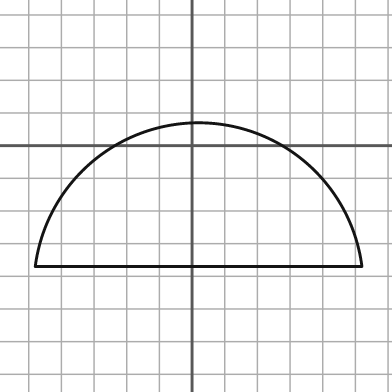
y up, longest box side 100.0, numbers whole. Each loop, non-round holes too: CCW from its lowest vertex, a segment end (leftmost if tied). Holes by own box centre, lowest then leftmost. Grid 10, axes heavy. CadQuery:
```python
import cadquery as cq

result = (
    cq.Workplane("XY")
    .moveTo(-48.0, -37.0)
    .lineTo(52.0, -37.0)
    .threePointArc((2.0, 7.0), (-48.0, -37.0))
    .close()
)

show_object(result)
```